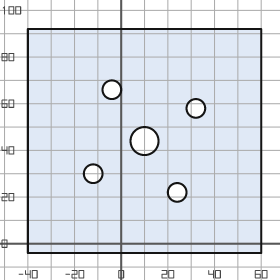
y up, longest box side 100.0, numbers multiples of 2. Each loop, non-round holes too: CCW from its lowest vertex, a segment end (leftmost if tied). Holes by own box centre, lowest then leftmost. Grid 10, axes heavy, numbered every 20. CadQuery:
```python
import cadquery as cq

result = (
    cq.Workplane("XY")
    .moveTo(-40.0, -4.0)
    .lineTo(60.0, -4.0)
    .lineTo(60.0, 92.0)
    .lineTo(-40.0, 92.0)
    .close()
    .moveTo(24.0, 22.0)
    .circle(4.0)
    .moveTo(-12.0, 30.0)
    .circle(4.0)
    .moveTo(10.0, 44.0)
    .circle(6.0)
    .moveTo(32.0, 58.0)
    .circle(4.0)
    .moveTo(-4.0, 66.0)
    .circle(4.0)
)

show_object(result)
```